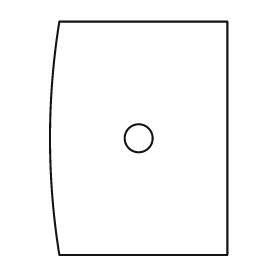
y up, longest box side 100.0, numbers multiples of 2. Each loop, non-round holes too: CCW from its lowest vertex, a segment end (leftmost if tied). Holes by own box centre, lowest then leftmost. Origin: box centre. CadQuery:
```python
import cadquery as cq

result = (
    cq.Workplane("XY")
    .moveTo(-34.0, -50.0)
    .lineTo(38.0, -50.0)
    .lineTo(38.0, 50.0)
    .lineTo(-34.0, 50.0)
    .threePointArc((-38.0, 0.0), (-34.0, -50.0))
    .close()
    .moveTo(0.0, 0.0)
    .circle(6.0)
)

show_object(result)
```